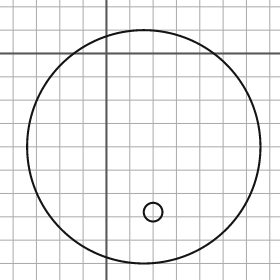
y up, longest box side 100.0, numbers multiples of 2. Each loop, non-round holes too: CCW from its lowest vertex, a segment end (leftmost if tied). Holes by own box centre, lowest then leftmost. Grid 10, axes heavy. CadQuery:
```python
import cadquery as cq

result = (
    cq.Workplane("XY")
    .moveTo(16.0, -40.0)
    .circle(50.0)
    .moveTo(20.0, -68.0)
    .circle(4.0)
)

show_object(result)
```